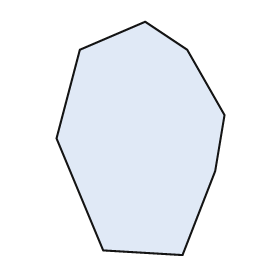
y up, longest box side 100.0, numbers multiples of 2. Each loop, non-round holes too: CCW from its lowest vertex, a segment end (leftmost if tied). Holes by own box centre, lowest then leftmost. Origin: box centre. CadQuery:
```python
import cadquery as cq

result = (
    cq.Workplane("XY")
    .moveTo(18.0, -50.0)
    .lineTo(32.0, -14.0)
    .lineTo(36.0, 10.0)
    .lineTo(20.0, 38.0)
    .lineTo(2.0, 50.0)
    .lineTo(-26.0, 38.0)
    .lineTo(-36.0, 0.0)
    .lineTo(-16.0, -48.0)
    .close()
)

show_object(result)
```